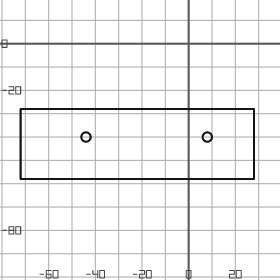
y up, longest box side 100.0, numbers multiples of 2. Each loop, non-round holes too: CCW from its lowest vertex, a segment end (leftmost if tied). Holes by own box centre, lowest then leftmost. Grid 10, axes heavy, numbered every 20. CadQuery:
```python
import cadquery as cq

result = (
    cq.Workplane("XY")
    .moveTo(-72.0, -58.0)
    .lineTo(28.0, -58.0)
    .lineTo(28.0, -28.0)
    .lineTo(-72.0, -28.0)
    .close()
    .moveTo(-44.0, -40.0)
    .circle(2.0)
    .moveTo(8.0, -40.0)
    .circle(2.0)
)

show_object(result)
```